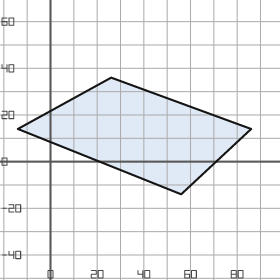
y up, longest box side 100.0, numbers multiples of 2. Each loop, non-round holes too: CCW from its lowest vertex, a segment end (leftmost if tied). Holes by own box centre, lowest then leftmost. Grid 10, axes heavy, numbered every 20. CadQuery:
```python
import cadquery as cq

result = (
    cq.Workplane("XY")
    .moveTo(56.0, -14.0)
    .lineTo(86.0, 14.0)
    .lineTo(26.0, 36.0)
    .lineTo(-14.0, 14.0)
    .close()
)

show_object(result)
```